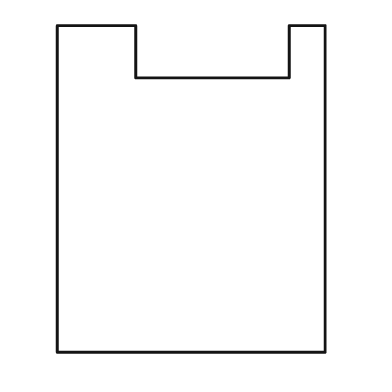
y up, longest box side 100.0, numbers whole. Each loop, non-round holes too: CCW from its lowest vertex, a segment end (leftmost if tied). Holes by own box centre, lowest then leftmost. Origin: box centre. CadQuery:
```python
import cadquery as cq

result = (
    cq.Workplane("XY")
    .moveTo(-41.0, -50.0)
    .lineTo(41.0, -50.0)
    .lineTo(41.0, 50.0)
    .lineTo(30.0, 50.0)
    .lineTo(30.0, 34.0)
    .lineTo(-17.0, 34.0)
    .lineTo(-17.0, 50.0)
    .lineTo(-41.0, 50.0)
    .close()
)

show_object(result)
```